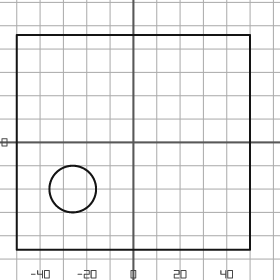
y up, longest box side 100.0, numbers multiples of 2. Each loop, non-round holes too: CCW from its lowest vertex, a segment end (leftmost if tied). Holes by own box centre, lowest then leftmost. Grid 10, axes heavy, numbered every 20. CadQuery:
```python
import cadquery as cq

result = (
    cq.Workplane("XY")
    .moveTo(-50.0, -46.0)
    .lineTo(50.0, -46.0)
    .lineTo(50.0, 46.0)
    .lineTo(-50.0, 46.0)
    .close()
    .moveTo(-26.0, -20.0)
    .circle(10.0)
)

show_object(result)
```